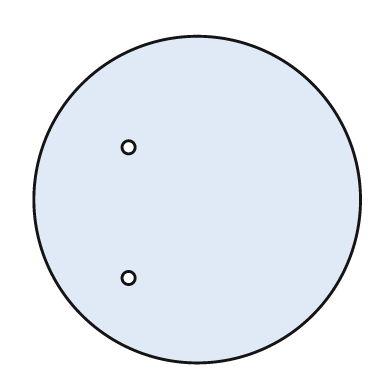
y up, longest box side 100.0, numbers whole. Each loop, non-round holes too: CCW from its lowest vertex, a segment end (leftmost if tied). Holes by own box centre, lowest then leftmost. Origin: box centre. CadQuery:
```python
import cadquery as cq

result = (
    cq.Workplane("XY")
    .moveTo(0.0, 0.0)
    .circle(50.0)
    .moveTo(-21.0, -24.0)
    .circle(2.0)
    .moveTo(-21.0, 16.0)
    .circle(2.0)
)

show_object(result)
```